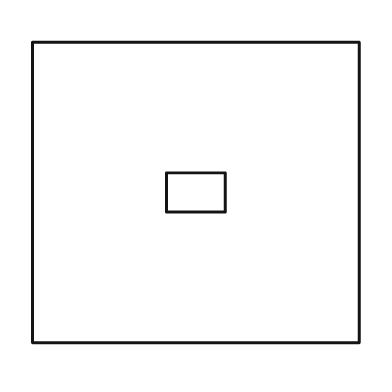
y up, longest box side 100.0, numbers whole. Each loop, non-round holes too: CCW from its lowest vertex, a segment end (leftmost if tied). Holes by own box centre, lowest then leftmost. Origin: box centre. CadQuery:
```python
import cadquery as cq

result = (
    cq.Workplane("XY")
    .moveTo(-50.0, -46.0)
    .lineTo(50.0, -46.0)
    .lineTo(50.0, 46.0)
    .lineTo(-50.0, 46.0)
    .close()
    .moveTo(-9.0, -6.0)
    .lineTo(9.0, -6.0)
    .lineTo(9.0, 6.0)
    .lineTo(-9.0, 6.0)
    .close()
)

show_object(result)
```